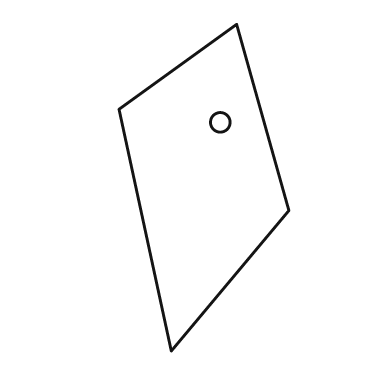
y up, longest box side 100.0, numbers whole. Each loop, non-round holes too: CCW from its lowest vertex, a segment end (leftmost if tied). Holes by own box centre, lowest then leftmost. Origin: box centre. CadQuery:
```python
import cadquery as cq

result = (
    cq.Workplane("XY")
    .moveTo(-10.0, -50.0)
    .lineTo(26.0, -7.0)
    .lineTo(10.0, 50.0)
    .lineTo(-26.0, 24.0)
    .close()
    .moveTo(5.0, 20.0)
    .circle(3.0)
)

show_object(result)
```